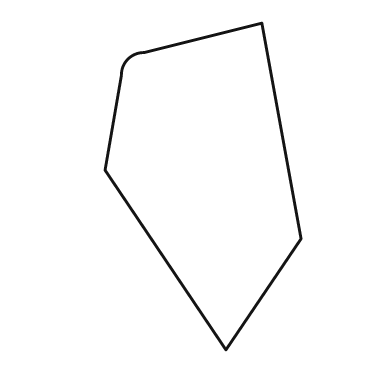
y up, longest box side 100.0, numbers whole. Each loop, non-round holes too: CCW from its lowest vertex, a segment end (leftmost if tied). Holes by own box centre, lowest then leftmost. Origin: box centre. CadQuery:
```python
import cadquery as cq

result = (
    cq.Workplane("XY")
    .moveTo(7.0, -50.0)
    .lineTo(30.0, -16.0)
    .lineTo(18.0, 50.0)
    .lineTo(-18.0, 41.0)
    .threePointArc((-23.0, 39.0), (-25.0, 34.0))
    .lineTo(-30.0, 5.0)
    .close()
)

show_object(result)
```